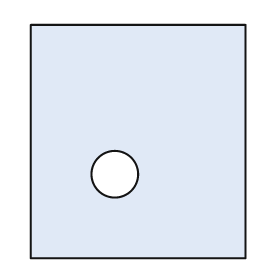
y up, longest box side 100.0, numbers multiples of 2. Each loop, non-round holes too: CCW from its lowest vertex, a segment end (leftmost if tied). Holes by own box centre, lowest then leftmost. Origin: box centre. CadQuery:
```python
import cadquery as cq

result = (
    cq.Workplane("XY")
    .moveTo(-46.0, -50.0)
    .lineTo(46.0, -50.0)
    .lineTo(46.0, 50.0)
    .lineTo(-46.0, 50.0)
    .close()
    .moveTo(-10.0, -14.0)
    .circle(10.0)
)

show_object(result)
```